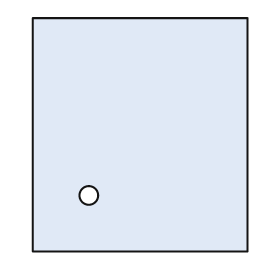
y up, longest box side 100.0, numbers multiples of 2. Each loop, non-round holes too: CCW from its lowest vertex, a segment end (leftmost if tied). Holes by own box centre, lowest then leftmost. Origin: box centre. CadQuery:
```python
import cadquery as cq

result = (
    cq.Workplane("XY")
    .moveTo(-46.0, -50.0)
    .lineTo(46.0, -50.0)
    .lineTo(46.0, 50.0)
    .lineTo(-46.0, 50.0)
    .close()
    .moveTo(-22.0, -26.0)
    .circle(4.0)
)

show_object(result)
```